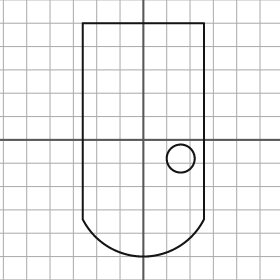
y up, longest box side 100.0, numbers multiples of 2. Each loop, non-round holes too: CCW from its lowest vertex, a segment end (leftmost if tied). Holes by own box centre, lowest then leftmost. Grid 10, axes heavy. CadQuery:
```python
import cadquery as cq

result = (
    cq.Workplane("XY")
    .moveTo(-26.0, -34.0)
    .threePointArc((0.0, -50.0), (26.0, -34.0))
    .lineTo(26.0, 50.0)
    .lineTo(-26.0, 50.0)
    .close()
    .moveTo(16.0, -8.0)
    .circle(6.0)
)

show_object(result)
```